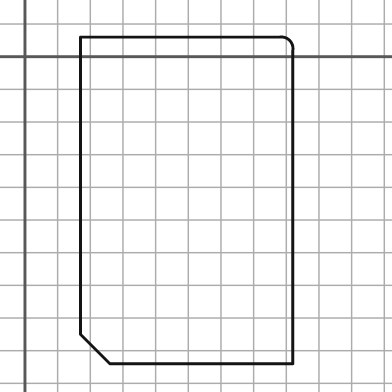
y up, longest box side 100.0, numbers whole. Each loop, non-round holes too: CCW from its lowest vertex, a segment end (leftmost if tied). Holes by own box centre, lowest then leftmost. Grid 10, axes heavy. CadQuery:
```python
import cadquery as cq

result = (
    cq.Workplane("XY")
    .moveTo(26.0, -94.0)
    .lineTo(82.0, -94.0)
    .lineTo(82.0, 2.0)
    .threePointArc((81.0, 5.0), (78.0, 6.0))
    .lineTo(17.0, 6.0)
    .lineTo(17.0, -85.0)
    .close()
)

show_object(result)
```